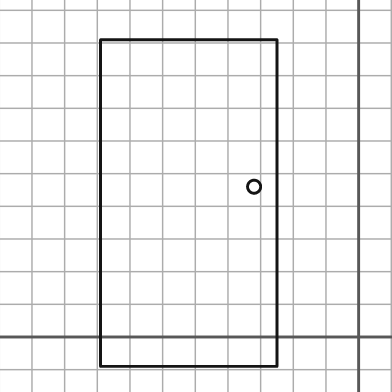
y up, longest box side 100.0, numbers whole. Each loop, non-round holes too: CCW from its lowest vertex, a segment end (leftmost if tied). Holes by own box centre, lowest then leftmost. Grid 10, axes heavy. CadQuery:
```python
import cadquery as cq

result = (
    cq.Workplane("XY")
    .moveTo(-79.0, -9.0)
    .lineTo(-25.0, -9.0)
    .lineTo(-25.0, 91.0)
    .lineTo(-79.0, 91.0)
    .close()
    .moveTo(-32.0, 46.0)
    .circle(2.0)
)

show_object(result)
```